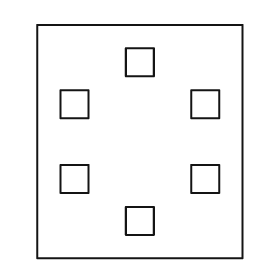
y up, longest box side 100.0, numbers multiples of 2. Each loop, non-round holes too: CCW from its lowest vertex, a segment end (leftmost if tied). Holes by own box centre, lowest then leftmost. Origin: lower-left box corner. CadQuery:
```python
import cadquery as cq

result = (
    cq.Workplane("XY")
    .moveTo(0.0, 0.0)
    .lineTo(88.0, 0.0)
    .lineTo(88.0, 100.0)
    .lineTo(0.0, 100.0)
    .close()
    .moveTo(38.0, 10.0)
    .lineTo(50.0, 10.0)
    .lineTo(50.0, 22.0)
    .lineTo(38.0, 22.0)
    .close()
    .moveTo(10.0, 28.0)
    .lineTo(22.0, 28.0)
    .lineTo(22.0, 40.0)
    .lineTo(10.0, 40.0)
    .close()
    .moveTo(66.0, 28.0)
    .lineTo(78.0, 28.0)
    .lineTo(78.0, 40.0)
    .lineTo(66.0, 40.0)
    .close()
    .moveTo(10.0, 60.0)
    .lineTo(22.0, 60.0)
    .lineTo(22.0, 72.0)
    .lineTo(10.0, 72.0)
    .close()
    .moveTo(66.0, 60.0)
    .lineTo(78.0, 60.0)
    .lineTo(78.0, 72.0)
    .lineTo(66.0, 72.0)
    .close()
    .moveTo(38.0, 78.0)
    .lineTo(50.0, 78.0)
    .lineTo(50.0, 90.0)
    .lineTo(38.0, 90.0)
    .close()
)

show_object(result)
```